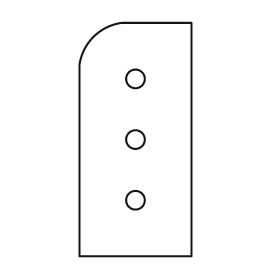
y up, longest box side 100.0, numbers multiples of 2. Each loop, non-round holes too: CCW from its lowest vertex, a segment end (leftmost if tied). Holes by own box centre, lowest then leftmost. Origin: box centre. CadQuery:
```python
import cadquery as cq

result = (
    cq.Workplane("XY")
    .moveTo(-24.0, -50.0)
    .lineTo(24.0, -50.0)
    .lineTo(24.0, 50.0)
    .lineTo(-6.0, 50.0)
    .threePointArc((-18.0, 44.0), (-24.0, 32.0))
    .close()
    .moveTo(0.0, -26.0)
    .circle(4.0)
    .moveTo(0.0, 0.0)
    .circle(4.0)
    .moveTo(0.0, 26.0)
    .circle(4.0)
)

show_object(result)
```